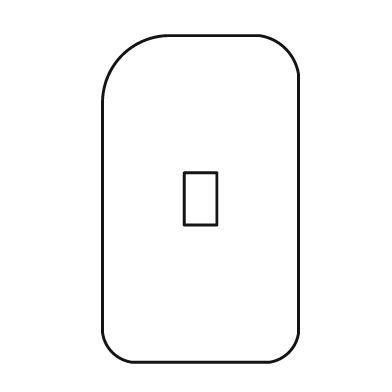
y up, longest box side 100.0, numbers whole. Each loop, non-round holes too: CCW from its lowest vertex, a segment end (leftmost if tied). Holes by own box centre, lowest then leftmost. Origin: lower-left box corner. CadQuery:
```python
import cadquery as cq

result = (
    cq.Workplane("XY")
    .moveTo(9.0, 0.0)
    .lineTo(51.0, 0.0)
    .threePointArc((57.0, 3.0), (60.0, 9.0))
    .lineTo(60.0, 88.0)
    .threePointArc((56.0, 96.0), (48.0, 100.0))
    .lineTo(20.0, 100.0)
    .threePointArc((6.0, 94.0), (0.0, 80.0))
    .lineTo(0.0, 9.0)
    .threePointArc((3.0, 3.0), (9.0, 0.0))
    .close()
    .moveTo(25.0, 42.0)
    .lineTo(35.0, 42.0)
    .lineTo(35.0, 58.0)
    .lineTo(25.0, 58.0)
    .close()
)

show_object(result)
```